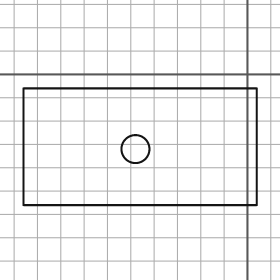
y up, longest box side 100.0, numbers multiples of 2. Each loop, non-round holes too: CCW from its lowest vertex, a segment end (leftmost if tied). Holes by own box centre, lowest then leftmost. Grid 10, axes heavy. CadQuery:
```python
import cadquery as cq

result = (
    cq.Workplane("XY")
    .moveTo(-96.0, -56.0)
    .lineTo(4.0, -56.0)
    .lineTo(4.0, -6.0)
    .lineTo(-96.0, -6.0)
    .close()
    .moveTo(-48.0, -32.0)
    .circle(6.0)
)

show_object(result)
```